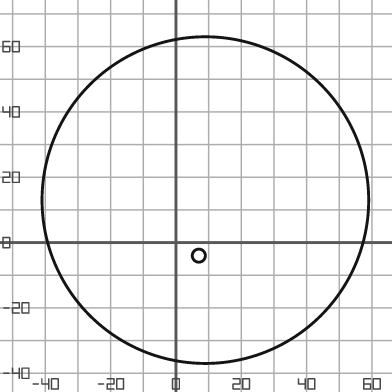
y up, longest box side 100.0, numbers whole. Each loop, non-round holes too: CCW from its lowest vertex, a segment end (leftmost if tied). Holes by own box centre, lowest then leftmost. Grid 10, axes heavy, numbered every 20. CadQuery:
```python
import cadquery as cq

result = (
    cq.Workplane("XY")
    .moveTo(9.0, 13.0)
    .circle(50.0)
    .moveTo(7.0, -4.0)
    .circle(2.0)
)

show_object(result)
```